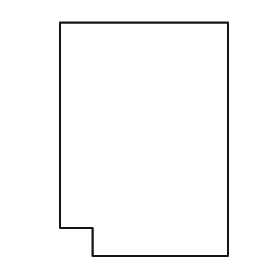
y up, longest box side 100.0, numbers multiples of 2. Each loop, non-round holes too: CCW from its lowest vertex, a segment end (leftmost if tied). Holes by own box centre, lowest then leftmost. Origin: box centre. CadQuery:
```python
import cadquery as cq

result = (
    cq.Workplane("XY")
    .moveTo(-22.0, -50.0)
    .lineTo(36.0, -50.0)
    .lineTo(36.0, 50.0)
    .lineTo(-36.0, 50.0)
    .lineTo(-36.0, -38.0)
    .lineTo(-22.0, -38.0)
    .close()
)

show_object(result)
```